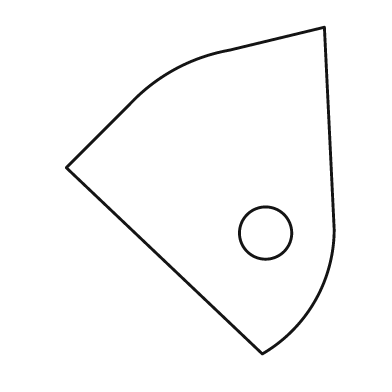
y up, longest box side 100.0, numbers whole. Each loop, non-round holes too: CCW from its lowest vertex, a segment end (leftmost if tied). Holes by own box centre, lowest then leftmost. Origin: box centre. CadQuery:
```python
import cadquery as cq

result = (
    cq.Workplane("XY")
    .moveTo(19.0, -50.0)
    .threePointArc((35.0, -34.0), (41.0, -12.0))
    .lineTo(38.0, 50.0)
    .lineTo(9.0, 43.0)
    .threePointArc((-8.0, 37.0), (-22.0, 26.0))
    .lineTo(-41.0, 7.0)
    .close()
    .moveTo(20.0, -13.0)
    .circle(8.0)
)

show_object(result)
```